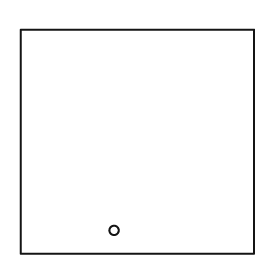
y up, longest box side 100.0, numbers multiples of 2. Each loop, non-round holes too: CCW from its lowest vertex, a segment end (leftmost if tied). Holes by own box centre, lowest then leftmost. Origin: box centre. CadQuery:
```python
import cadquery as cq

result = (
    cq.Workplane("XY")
    .moveTo(-50.0, -48.0)
    .lineTo(50.0, -48.0)
    .lineTo(50.0, 48.0)
    .lineTo(-50.0, 48.0)
    .close()
    .moveTo(-10.0, -38.0)
    .circle(2.0)
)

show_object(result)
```